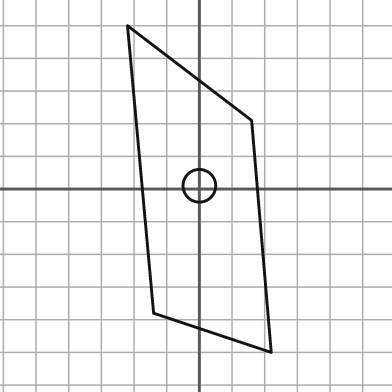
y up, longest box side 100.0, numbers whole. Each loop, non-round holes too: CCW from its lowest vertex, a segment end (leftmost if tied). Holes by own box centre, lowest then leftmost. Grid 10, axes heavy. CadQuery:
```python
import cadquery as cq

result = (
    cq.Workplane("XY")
    .moveTo(22.0, -50.0)
    .lineTo(16.0, 21.0)
    .lineTo(-22.0, 50.0)
    .lineTo(-14.0, -38.0)
    .close()
    .moveTo(0.0, 1.0)
    .circle(5.0)
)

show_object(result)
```